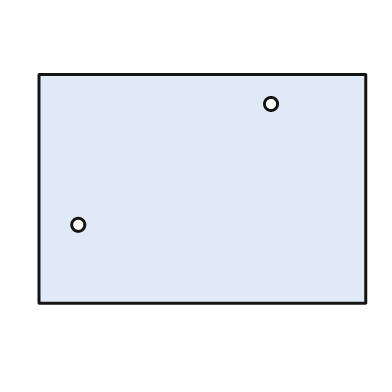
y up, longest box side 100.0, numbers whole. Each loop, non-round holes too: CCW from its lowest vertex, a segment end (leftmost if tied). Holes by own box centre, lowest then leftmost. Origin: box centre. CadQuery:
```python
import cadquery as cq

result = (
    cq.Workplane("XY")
    .moveTo(-50.0, -35.0)
    .lineTo(50.0, -35.0)
    .lineTo(50.0, 35.0)
    .lineTo(-50.0, 35.0)
    .close()
    .moveTo(-38.0, -11.0)
    .circle(2.0)
    .moveTo(21.0, 26.0)
    .circle(2.0)
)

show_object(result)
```